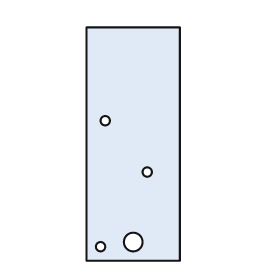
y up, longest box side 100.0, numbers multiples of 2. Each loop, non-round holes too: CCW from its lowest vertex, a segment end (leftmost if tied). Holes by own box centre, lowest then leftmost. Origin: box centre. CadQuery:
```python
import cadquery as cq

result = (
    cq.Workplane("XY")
    .moveTo(-20.0, -50.0)
    .lineTo(20.0, -50.0)
    .lineTo(20.0, 50.0)
    .lineTo(-20.0, 50.0)
    .close()
    .moveTo(-14.0, -44.0)
    .circle(2.0)
    .moveTo(0.0, -42.0)
    .circle(4.0)
    .moveTo(6.0, -12.0)
    .circle(2.0)
    .moveTo(-12.0, 10.0)
    .circle(2.0)
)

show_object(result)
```